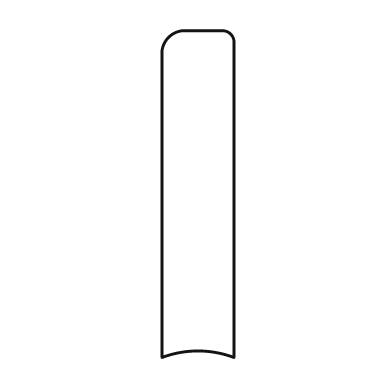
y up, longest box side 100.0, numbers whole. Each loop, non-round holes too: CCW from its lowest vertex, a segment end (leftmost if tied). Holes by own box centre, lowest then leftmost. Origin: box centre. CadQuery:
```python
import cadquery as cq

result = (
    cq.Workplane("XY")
    .moveTo(-11.0, -50.0)
    .threePointArc((0.0, -48.0), (11.0, -50.0))
    .lineTo(11.0, 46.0)
    .threePointArc((10.0, 49.0), (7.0, 50.0))
    .lineTo(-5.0, 50.0)
    .threePointArc((-9.0, 48.0), (-11.0, 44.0))
    .close()
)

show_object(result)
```